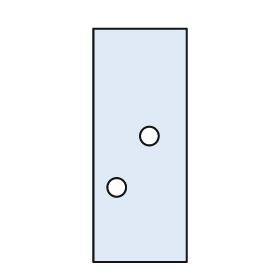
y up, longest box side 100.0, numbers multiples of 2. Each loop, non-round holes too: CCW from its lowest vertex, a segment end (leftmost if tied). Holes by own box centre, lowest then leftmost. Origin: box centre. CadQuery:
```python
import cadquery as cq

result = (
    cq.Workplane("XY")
    .moveTo(-20.0, -50.0)
    .lineTo(20.0, -50.0)
    .lineTo(20.0, 50.0)
    .lineTo(-20.0, 50.0)
    .close()
    .moveTo(-10.0, -18.0)
    .circle(4.0)
    .moveTo(4.0, 4.0)
    .circle(4.0)
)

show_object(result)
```